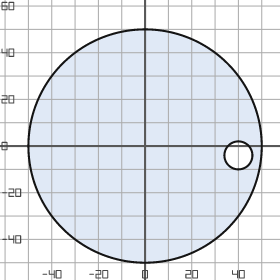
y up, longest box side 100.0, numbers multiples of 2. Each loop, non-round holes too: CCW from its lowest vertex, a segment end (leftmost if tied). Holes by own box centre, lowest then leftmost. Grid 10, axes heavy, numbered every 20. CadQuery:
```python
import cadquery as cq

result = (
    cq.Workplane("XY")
    .moveTo(0.0, 0.0)
    .circle(50.0)
    .moveTo(40.0, -4.0)
    .circle(6.0)
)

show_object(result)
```